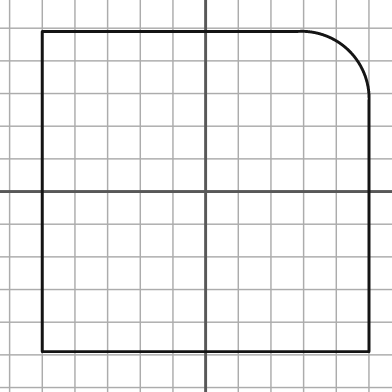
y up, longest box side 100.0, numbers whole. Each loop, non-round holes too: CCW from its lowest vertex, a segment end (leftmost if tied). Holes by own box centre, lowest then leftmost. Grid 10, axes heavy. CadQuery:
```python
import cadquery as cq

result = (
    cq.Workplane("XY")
    .moveTo(-50.0, -49.0)
    .lineTo(50.0, -49.0)
    .lineTo(50.0, 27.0)
    .threePointArc((44.0, 43.0), (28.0, 49.0))
    .lineTo(-50.0, 49.0)
    .close()
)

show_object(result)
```